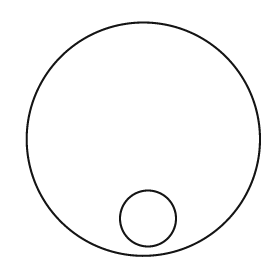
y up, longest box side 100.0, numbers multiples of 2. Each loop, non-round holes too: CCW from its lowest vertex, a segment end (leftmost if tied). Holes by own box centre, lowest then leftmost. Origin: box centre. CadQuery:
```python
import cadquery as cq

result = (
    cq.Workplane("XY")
    .moveTo(0.0, 0.0)
    .circle(50.0)
    .moveTo(2.0, -34.0)
    .circle(12.0)
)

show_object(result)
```